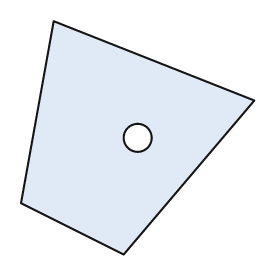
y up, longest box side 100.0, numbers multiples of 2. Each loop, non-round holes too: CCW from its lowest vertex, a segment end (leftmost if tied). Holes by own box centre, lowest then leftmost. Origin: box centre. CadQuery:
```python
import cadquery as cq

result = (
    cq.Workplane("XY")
    .moveTo(-6.0, -50.0)
    .lineTo(50.0, 16.0)
    .lineTo(-36.0, 50.0)
    .lineTo(-50.0, -28.0)
    .close()
    .moveTo(0.0, 0.0)
    .circle(6.0)
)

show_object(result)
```